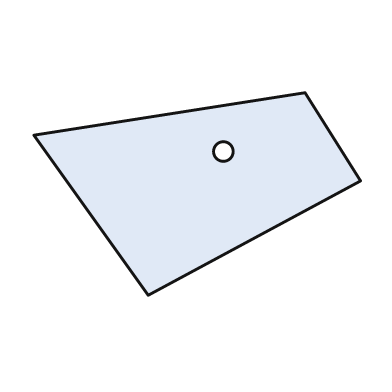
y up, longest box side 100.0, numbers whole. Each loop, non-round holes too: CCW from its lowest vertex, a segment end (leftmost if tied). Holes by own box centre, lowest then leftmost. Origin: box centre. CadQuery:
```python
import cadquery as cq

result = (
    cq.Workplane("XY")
    .moveTo(-15.0, -31.0)
    .lineTo(50.0, 4.0)
    .lineTo(33.0, 31.0)
    .lineTo(-50.0, 18.0)
    .close()
    .moveTo(8.0, 13.0)
    .circle(3.0)
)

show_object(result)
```